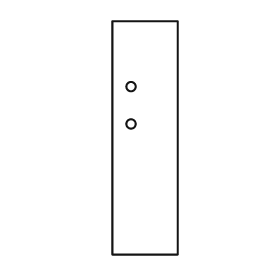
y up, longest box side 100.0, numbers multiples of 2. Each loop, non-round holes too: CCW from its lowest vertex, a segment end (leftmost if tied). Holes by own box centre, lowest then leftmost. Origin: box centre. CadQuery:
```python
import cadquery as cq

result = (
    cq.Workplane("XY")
    .moveTo(-14.0, -50.0)
    .lineTo(14.0, -50.0)
    .lineTo(14.0, 50.0)
    .lineTo(-14.0, 50.0)
    .close()
    .moveTo(-6.0, 6.0)
    .circle(2.0)
    .moveTo(-6.0, 22.0)
    .circle(2.0)
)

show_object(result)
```